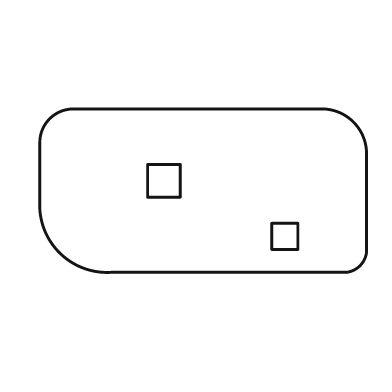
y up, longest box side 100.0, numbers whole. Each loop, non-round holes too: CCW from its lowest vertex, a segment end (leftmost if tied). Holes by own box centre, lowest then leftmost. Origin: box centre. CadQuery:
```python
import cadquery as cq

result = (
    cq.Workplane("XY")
    .moveTo(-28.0, -25.0)
    .lineTo(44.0, -25.0)
    .threePointArc((48.0, -23.0), (50.0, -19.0))
    .lineTo(50.0, 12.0)
    .threePointArc((46.0, 21.0), (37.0, 25.0))
    .lineTo(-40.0, 25.0)
    .threePointArc((-47.0, 22.0), (-50.0, 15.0))
    .lineTo(-50.0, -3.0)
    .threePointArc((-44.0, -19.0), (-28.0, -25.0))
    .close()
    .moveTo(21.0, -18.0)
    .lineTo(29.0, -18.0)
    .lineTo(29.0, -10.0)
    .lineTo(21.0, -10.0)
    .close()
    .moveTo(-17.0, -2.0)
    .lineTo(-7.0, -2.0)
    .lineTo(-7.0, 8.0)
    .lineTo(-17.0, 8.0)
    .close()
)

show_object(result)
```